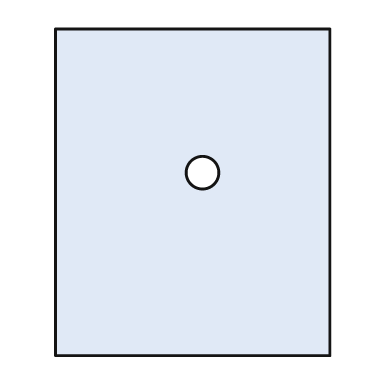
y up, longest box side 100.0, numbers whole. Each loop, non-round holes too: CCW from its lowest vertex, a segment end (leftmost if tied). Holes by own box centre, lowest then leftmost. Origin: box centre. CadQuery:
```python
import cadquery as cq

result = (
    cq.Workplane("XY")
    .moveTo(-42.0, -50.0)
    .lineTo(42.0, -50.0)
    .lineTo(42.0, 50.0)
    .lineTo(-42.0, 50.0)
    .close()
    .moveTo(3.0, 6.0)
    .circle(5.0)
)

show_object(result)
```